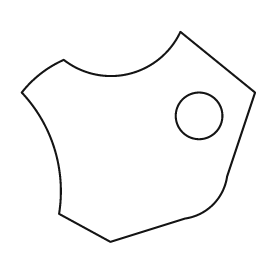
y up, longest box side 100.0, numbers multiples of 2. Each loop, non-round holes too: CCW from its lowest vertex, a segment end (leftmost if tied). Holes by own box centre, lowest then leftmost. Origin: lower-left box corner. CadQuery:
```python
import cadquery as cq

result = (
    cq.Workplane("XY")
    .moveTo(38.0, 0.0)
    .lineTo(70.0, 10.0)
    .threePointArc((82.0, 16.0), (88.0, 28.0))
    .lineTo(100.0, 64.0)
    .lineTo(68.0, 90.0)
    .threePointArc((46.0, 72.0), (18.0, 78.0))
    .threePointArc((8.0, 72.0), (0.0, 64.0))
    .threePointArc((14.0, 40.0), (16.0, 12.0))
    .close()
    .moveTo(76.0, 54.0)
    .circle(10.0)
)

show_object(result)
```